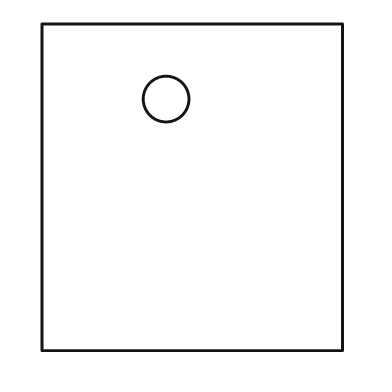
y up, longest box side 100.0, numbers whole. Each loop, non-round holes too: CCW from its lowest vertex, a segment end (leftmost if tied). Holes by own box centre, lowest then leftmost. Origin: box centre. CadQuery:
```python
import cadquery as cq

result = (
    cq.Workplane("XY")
    .moveTo(-46.0, -50.0)
    .lineTo(46.0, -50.0)
    .lineTo(46.0, 50.0)
    .lineTo(-46.0, 50.0)
    .close()
    .moveTo(-8.0, 27.0)
    .circle(7.0)
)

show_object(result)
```